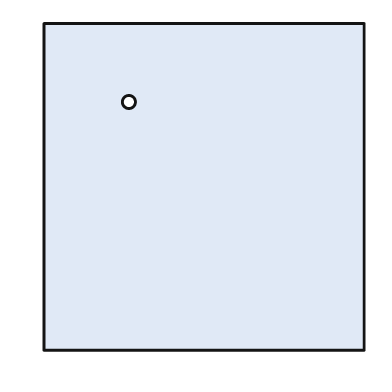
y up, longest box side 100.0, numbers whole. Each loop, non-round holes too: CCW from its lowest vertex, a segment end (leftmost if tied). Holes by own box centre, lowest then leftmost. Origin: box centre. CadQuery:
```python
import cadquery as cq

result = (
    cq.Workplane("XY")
    .moveTo(-49.0, -50.0)
    .lineTo(49.0, -50.0)
    .lineTo(49.0, 50.0)
    .lineTo(-49.0, 50.0)
    .close()
    .moveTo(-23.0, 26.0)
    .circle(2.0)
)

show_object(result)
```